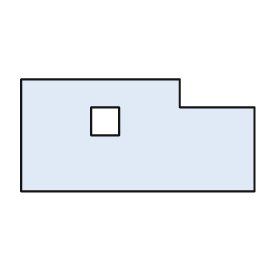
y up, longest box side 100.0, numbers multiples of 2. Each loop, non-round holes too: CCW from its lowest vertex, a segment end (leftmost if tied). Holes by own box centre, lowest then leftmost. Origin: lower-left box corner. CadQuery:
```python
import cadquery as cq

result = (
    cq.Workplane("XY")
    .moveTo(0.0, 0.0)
    .lineTo(100.0, 0.0)
    .lineTo(100.0, 36.0)
    .lineTo(68.0, 36.0)
    .lineTo(68.0, 48.0)
    .lineTo(0.0, 48.0)
    .close()
    .moveTo(30.0, 24.0)
    .lineTo(42.0, 24.0)
    .lineTo(42.0, 36.0)
    .lineTo(30.0, 36.0)
    .close()
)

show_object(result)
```